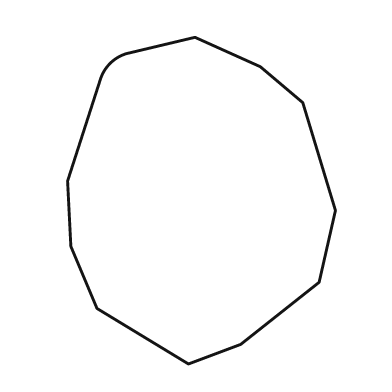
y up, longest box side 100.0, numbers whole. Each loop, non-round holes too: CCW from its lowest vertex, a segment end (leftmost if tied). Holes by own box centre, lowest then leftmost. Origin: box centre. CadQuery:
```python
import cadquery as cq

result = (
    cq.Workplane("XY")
    .moveTo(-4.0, -50.0)
    .lineTo(12.0, -44.0)
    .lineTo(36.0, -25.0)
    .lineTo(41.0, -3.0)
    .lineTo(31.0, 30.0)
    .lineTo(18.0, 41.0)
    .lineTo(-2.0, 50.0)
    .lineTo(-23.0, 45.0)
    .threePointArc((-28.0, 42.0), (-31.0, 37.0))
    .lineTo(-41.0, 6.0)
    .lineTo(-40.0, -14.0)
    .lineTo(-32.0, -33.0)
    .close()
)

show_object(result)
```